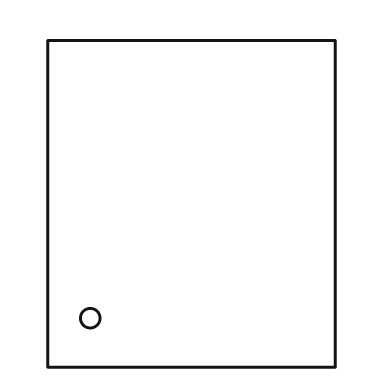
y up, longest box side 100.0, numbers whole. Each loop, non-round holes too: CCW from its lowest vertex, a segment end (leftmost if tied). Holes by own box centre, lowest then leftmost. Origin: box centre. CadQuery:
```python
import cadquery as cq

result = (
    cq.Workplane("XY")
    .moveTo(-44.0, -50.0)
    .lineTo(44.0, -50.0)
    .lineTo(44.0, 50.0)
    .lineTo(-44.0, 50.0)
    .close()
    .moveTo(-31.0, -35.0)
    .circle(3.0)
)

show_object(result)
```